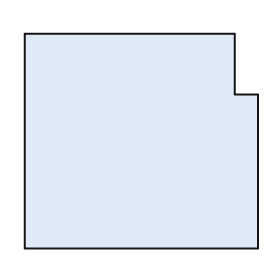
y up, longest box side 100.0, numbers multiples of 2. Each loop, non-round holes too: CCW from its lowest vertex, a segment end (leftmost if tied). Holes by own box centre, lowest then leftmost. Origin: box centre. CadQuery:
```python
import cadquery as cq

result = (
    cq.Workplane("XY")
    .moveTo(-50.0, -46.0)
    .lineTo(50.0, -46.0)
    .lineTo(50.0, 20.0)
    .lineTo(40.0, 20.0)
    .lineTo(40.0, 46.0)
    .lineTo(-50.0, 46.0)
    .close()
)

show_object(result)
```